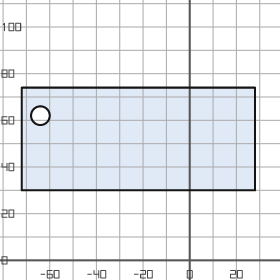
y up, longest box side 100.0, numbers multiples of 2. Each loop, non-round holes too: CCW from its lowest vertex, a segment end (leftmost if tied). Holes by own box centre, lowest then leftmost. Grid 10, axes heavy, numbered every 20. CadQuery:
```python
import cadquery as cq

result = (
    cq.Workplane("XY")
    .moveTo(-72.0, 30.0)
    .lineTo(28.0, 30.0)
    .lineTo(28.0, 74.0)
    .lineTo(-72.0, 74.0)
    .close()
    .moveTo(-64.0, 62.0)
    .circle(4.0)
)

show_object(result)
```